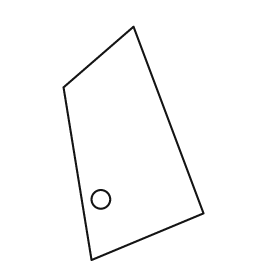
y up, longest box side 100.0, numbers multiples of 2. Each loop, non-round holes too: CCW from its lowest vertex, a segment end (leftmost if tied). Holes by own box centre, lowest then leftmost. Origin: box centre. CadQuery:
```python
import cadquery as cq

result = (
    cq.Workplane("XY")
    .moveTo(-18.0, -50.0)
    .lineTo(30.0, -30.0)
    .lineTo(0.0, 50.0)
    .lineTo(-30.0, 24.0)
    .close()
    .moveTo(-14.0, -24.0)
    .circle(4.0)
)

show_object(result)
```